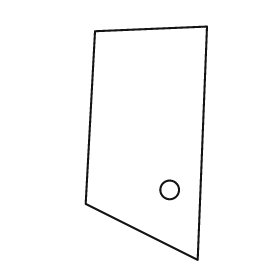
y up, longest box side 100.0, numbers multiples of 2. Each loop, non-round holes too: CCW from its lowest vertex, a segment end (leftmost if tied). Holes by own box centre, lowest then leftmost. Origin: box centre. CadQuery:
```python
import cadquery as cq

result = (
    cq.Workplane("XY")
    .moveTo(22.0, -50.0)
    .lineTo(26.0, 50.0)
    .lineTo(-22.0, 48.0)
    .lineTo(-26.0, -26.0)
    .close()
    .moveTo(10.0, -20.0)
    .circle(4.0)
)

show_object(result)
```